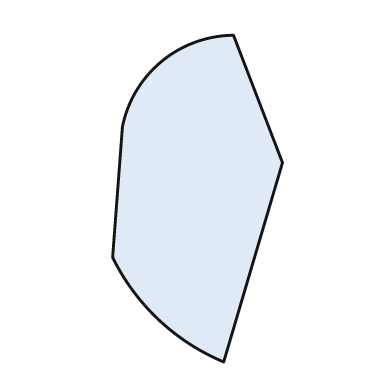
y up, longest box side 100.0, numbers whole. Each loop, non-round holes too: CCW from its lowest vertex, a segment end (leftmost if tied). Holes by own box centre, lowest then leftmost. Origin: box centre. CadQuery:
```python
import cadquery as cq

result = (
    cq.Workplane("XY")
    .moveTo(8.0, -50.0)
    .lineTo(26.0, 11.0)
    .lineTo(11.0, 50.0)
    .threePointArc((-11.0, 42.0), (-23.0, 22.0))
    .lineTo(-26.0, -18.0)
    .threePointArc((-12.0, -37.0), (8.0, -50.0))
    .close()
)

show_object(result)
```